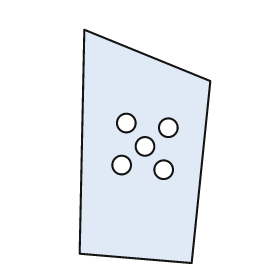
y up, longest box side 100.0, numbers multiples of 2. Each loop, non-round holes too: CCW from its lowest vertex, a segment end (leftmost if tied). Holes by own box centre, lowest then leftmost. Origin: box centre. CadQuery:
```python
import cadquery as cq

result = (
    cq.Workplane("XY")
    .moveTo(20.0, -50.0)
    .lineTo(28.0, 28.0)
    .lineTo(-26.0, 50.0)
    .lineTo(-28.0, -46.0)
    .close()
    .moveTo(8.0, -10.0)
    .circle(4.0)
    .moveTo(-10.0, -8.0)
    .circle(4.0)
    .moveTo(0.0, 0.0)
    .circle(4.0)
    .moveTo(10.0, 8.0)
    .circle(4.0)
    .moveTo(-8.0, 10.0)
    .circle(4.0)
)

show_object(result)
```